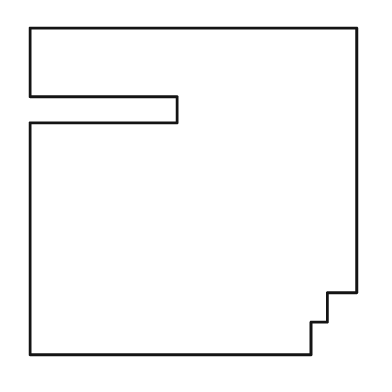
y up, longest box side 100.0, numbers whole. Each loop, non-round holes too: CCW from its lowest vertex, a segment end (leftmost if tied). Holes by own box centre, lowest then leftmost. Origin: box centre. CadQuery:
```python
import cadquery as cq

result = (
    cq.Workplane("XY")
    .moveTo(-50.0, -50.0)
    .lineTo(36.0, -50.0)
    .lineTo(36.0, -40.0)
    .lineTo(41.0, -40.0)
    .lineTo(41.0, -31.0)
    .lineTo(50.0, -31.0)
    .lineTo(50.0, 50.0)
    .lineTo(-50.0, 50.0)
    .lineTo(-50.0, 29.0)
    .lineTo(-5.0, 29.0)
    .lineTo(-5.0, 21.0)
    .lineTo(-50.0, 21.0)
    .close()
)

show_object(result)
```